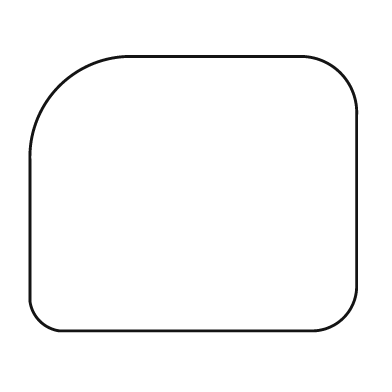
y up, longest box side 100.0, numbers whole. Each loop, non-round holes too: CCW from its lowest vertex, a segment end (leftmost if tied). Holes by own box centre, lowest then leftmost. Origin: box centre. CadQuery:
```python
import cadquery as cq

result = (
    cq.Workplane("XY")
    .moveTo(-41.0, -42.0)
    .lineTo(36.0, -42.0)
    .threePointArc((46.0, -38.0), (50.0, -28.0))
    .lineTo(50.0, 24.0)
    .threePointArc((45.0, 37.0), (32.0, 42.0))
    .lineTo(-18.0, 42.0)
    .threePointArc((-41.0, 33.0), (-50.0, 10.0))
    .lineTo(-50.0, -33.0)
    .threePointArc((-47.0, -39.0), (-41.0, -42.0))
    .close()
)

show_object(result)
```